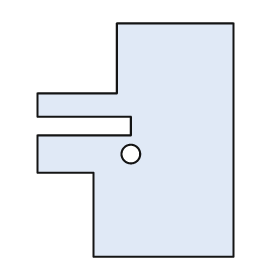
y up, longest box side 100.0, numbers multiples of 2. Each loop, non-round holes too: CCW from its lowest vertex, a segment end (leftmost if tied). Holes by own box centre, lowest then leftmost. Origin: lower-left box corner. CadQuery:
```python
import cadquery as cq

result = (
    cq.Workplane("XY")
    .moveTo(24.0, 0.0)
    .lineTo(84.0, 0.0)
    .lineTo(84.0, 100.0)
    .lineTo(34.0, 100.0)
    .lineTo(34.0, 70.0)
    .lineTo(0.0, 70.0)
    .lineTo(0.0, 60.0)
    .lineTo(40.0, 60.0)
    .lineTo(40.0, 52.0)
    .lineTo(0.0, 52.0)
    .lineTo(0.0, 36.0)
    .lineTo(24.0, 36.0)
    .close()
    .moveTo(40.0, 44.0)
    .circle(4.0)
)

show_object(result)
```